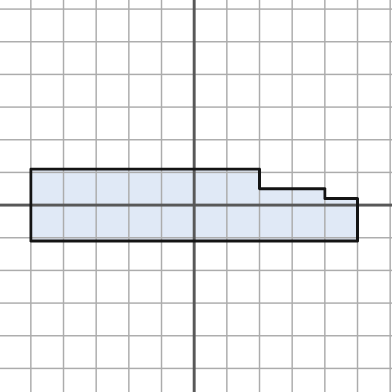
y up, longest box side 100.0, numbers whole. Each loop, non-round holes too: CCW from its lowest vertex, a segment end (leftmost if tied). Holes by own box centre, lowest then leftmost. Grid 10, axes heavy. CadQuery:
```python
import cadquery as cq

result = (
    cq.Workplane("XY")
    .moveTo(-50.0, -11.0)
    .lineTo(50.0, -11.0)
    .lineTo(50.0, 2.0)
    .lineTo(40.0, 2.0)
    .lineTo(40.0, 5.0)
    .lineTo(20.0, 5.0)
    .lineTo(20.0, 11.0)
    .lineTo(-50.0, 11.0)
    .close()
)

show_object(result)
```